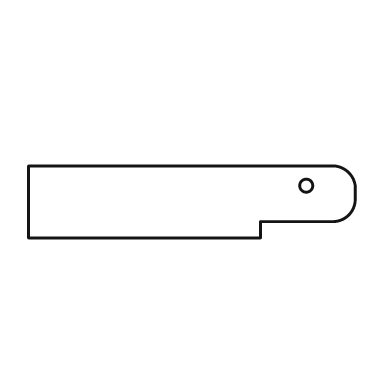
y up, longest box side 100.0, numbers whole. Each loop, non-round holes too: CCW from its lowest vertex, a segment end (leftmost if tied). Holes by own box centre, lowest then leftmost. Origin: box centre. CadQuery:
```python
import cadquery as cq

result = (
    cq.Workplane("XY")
    .moveTo(-50.0, -11.0)
    .lineTo(21.0, -11.0)
    .lineTo(21.0, -6.0)
    .lineTo(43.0, -6.0)
    .threePointArc((48.0, -4.0), (50.0, 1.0))
    .lineTo(50.0, 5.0)
    .threePointArc((48.0, 9.0), (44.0, 11.0))
    .lineTo(-50.0, 11.0)
    .close()
    .moveTo(35.0, 5.0)
    .circle(2.0)
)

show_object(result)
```